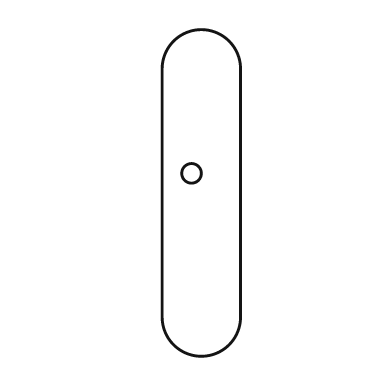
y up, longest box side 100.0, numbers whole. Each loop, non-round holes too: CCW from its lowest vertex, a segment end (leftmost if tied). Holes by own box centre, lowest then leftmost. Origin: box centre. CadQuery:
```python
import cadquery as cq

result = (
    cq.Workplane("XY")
    .moveTo(-12.0, -38.0)
    .threePointArc((0.0, -50.0), (12.0, -38.0))
    .lineTo(12.0, 38.0)
    .threePointArc((0.0, 50.0), (-12.0, 38.0))
    .close()
    .moveTo(-3.0, 6.0)
    .circle(3.0)
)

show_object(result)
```